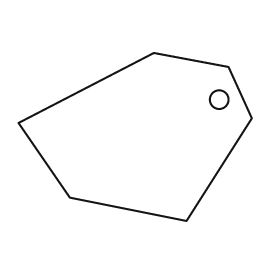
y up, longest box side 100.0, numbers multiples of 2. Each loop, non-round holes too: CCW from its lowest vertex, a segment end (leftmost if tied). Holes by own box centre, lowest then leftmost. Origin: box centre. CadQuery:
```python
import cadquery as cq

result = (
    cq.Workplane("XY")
    .moveTo(22.0, -36.0)
    .lineTo(50.0, 8.0)
    .lineTo(40.0, 30.0)
    .lineTo(8.0, 36.0)
    .lineTo(-50.0, 6.0)
    .lineTo(-28.0, -26.0)
    .close()
    .moveTo(36.0, 16.0)
    .circle(4.0)
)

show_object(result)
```